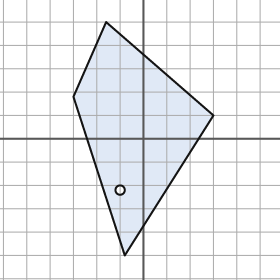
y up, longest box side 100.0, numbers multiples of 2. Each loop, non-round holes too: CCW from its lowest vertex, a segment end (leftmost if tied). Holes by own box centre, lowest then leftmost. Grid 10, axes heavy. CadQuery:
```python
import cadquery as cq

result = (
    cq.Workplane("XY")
    .moveTo(-8.0, -50.0)
    .lineTo(30.0, 10.0)
    .lineTo(-16.0, 50.0)
    .lineTo(-30.0, 18.0)
    .close()
    .moveTo(-10.0, -22.0)
    .circle(2.0)
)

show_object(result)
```